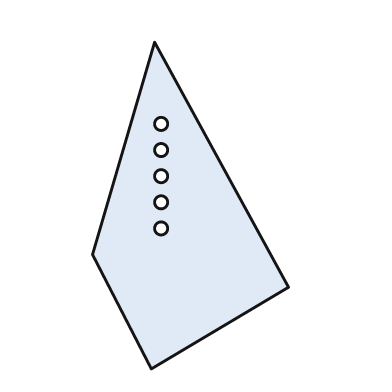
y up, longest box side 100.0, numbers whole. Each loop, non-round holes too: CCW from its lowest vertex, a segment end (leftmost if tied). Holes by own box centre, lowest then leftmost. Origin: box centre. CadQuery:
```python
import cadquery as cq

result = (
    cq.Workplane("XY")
    .moveTo(-12.0, -50.0)
    .lineTo(30.0, -25.0)
    .lineTo(-11.0, 50.0)
    .lineTo(-30.0, -15.0)
    .close()
    .moveTo(-9.0, -7.0)
    .circle(2.0)
    .moveTo(-9.0, 1.0)
    .circle(2.0)
    .moveTo(-9.0, 9.0)
    .circle(2.0)
    .moveTo(-9.0, 17.0)
    .circle(2.0)
    .moveTo(-9.0, 25.0)
    .circle(2.0)
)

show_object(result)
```